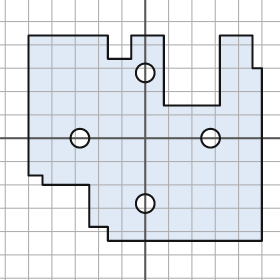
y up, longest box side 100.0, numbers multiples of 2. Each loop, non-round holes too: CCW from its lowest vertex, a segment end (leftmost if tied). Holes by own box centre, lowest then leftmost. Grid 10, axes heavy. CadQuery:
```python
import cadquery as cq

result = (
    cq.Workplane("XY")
    .moveTo(-16.0, -44.0)
    .lineTo(50.0, -44.0)
    .lineTo(50.0, 30.0)
    .lineTo(46.0, 30.0)
    .lineTo(46.0, 44.0)
    .lineTo(32.0, 44.0)
    .lineTo(32.0, 14.0)
    .lineTo(8.0, 14.0)
    .lineTo(8.0, 44.0)
    .lineTo(-6.0, 44.0)
    .lineTo(-6.0, 34.0)
    .lineTo(-16.0, 34.0)
    .lineTo(-16.0, 44.0)
    .lineTo(-50.0, 44.0)
    .lineTo(-50.0, -16.0)
    .lineTo(-44.0, -16.0)
    .lineTo(-44.0, -20.0)
    .lineTo(-24.0, -20.0)
    .lineTo(-24.0, -38.0)
    .lineTo(-16.0, -38.0)
    .close()
    .moveTo(0.0, -28.0)
    .circle(4.0)
    .moveTo(-28.0, 0.0)
    .circle(4.0)
    .moveTo(28.0, 0.0)
    .circle(4.0)
    .moveTo(0.0, 28.0)
    .circle(4.0)
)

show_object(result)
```